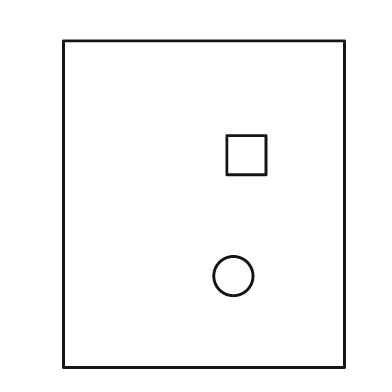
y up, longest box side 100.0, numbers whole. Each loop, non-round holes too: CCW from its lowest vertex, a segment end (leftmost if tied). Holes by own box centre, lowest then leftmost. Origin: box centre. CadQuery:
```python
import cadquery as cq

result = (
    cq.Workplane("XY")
    .moveTo(-43.0, -50.0)
    .lineTo(43.0, -50.0)
    .lineTo(43.0, 50.0)
    .lineTo(-43.0, 50.0)
    .close()
    .moveTo(9.0, -22.0)
    .circle(6.0)
    .moveTo(7.0, 9.0)
    .lineTo(19.0, 9.0)
    .lineTo(19.0, 21.0)
    .lineTo(7.0, 21.0)
    .close()
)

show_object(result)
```